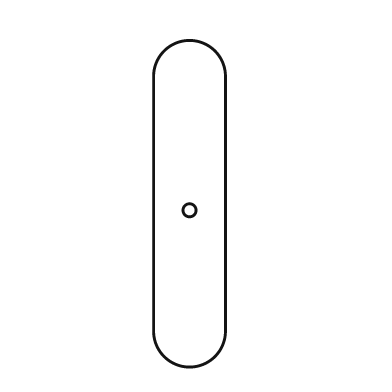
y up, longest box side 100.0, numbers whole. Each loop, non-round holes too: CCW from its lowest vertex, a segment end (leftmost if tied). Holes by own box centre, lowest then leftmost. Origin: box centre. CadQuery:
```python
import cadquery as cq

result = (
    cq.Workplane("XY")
    .moveTo(-11.0, -39.0)
    .threePointArc((0.0, -50.0), (11.0, -39.0))
    .lineTo(11.0, 39.0)
    .threePointArc((0.0, 50.0), (-11.0, 39.0))
    .close()
    .moveTo(0.0, -2.0)
    .circle(2.0)
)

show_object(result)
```